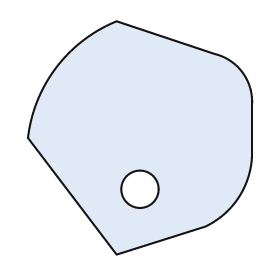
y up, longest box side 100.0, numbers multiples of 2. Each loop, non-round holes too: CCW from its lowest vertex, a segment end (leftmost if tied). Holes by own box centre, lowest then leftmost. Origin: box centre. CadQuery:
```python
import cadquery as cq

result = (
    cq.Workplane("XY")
    .moveTo(-10.0, -50.0)
    .lineTo(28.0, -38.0)
    .threePointArc((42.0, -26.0), (48.0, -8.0))
    .lineTo(48.0, 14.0)
    .threePointArc((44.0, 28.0), (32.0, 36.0))
    .lineTo(-10.0, 50.0)
    .threePointArc((-36.0, 30.0), (-48.0, 0.0))
    .close()
    .moveTo(0.0, -22.0)
    .circle(8.0)
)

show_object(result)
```